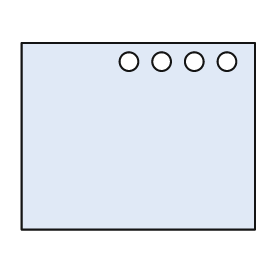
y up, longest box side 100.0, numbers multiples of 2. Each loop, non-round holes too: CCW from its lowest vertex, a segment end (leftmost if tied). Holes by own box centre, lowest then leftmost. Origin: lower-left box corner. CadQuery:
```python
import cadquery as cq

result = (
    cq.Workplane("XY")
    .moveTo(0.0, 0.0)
    .lineTo(100.0, 0.0)
    .lineTo(100.0, 80.0)
    .lineTo(0.0, 80.0)
    .close()
    .moveTo(46.0, 72.0)
    .circle(4.0)
    .moveTo(60.0, 72.0)
    .circle(4.0)
    .moveTo(74.0, 72.0)
    .circle(4.0)
    .moveTo(88.0, 72.0)
    .circle(4.0)
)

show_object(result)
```